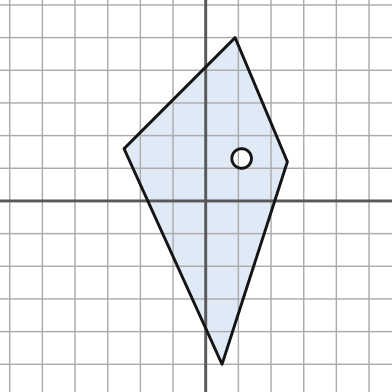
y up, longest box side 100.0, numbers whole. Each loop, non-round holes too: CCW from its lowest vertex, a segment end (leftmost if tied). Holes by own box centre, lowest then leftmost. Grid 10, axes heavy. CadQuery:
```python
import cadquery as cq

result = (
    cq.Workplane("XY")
    .moveTo(5.0, -50.0)
    .lineTo(25.0, 12.0)
    .lineTo(9.0, 50.0)
    .lineTo(-25.0, 16.0)
    .close()
    .moveTo(11.0, 13.0)
    .circle(3.0)
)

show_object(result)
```